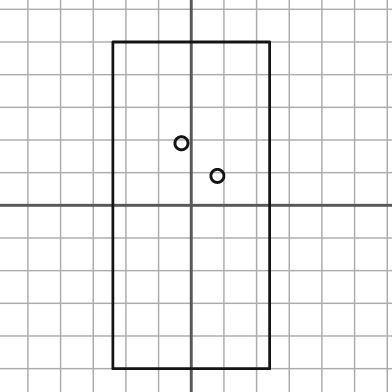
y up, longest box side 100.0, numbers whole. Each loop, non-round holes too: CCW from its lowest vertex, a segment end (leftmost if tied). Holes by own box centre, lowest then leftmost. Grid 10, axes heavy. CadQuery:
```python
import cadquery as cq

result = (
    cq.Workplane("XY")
    .moveTo(-24.0, -50.0)
    .lineTo(24.0, -50.0)
    .lineTo(24.0, 50.0)
    .lineTo(-24.0, 50.0)
    .close()
    .moveTo(8.0, 9.0)
    .circle(2.0)
    .moveTo(-3.0, 19.0)
    .circle(2.0)
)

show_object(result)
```